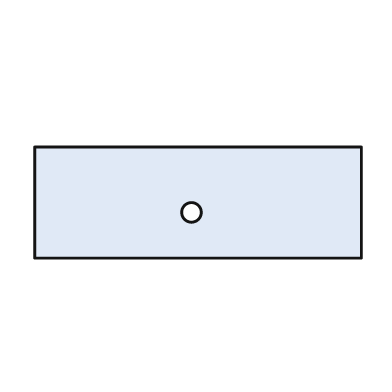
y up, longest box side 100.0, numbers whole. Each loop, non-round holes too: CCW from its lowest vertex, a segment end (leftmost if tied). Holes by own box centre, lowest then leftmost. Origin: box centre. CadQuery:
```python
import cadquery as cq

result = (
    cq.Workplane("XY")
    .moveTo(-50.0, -17.0)
    .lineTo(50.0, -17.0)
    .lineTo(50.0, 17.0)
    .lineTo(-50.0, 17.0)
    .close()
    .moveTo(-2.0, -3.0)
    .circle(3.0)
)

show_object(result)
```